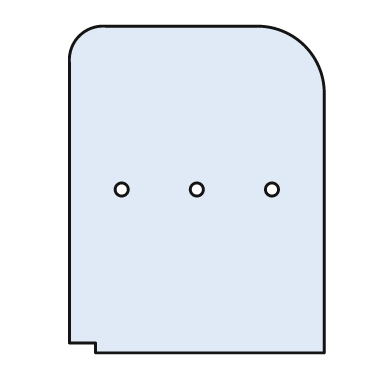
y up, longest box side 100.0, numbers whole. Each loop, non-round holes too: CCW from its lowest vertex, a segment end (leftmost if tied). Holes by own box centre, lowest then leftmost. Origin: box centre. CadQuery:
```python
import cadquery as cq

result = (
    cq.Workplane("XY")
    .moveTo(-31.0, -50.0)
    .lineTo(39.0, -50.0)
    .lineTo(39.0, 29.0)
    .threePointArc((33.0, 44.0), (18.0, 50.0))
    .lineTo(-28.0, 50.0)
    .threePointArc((-36.0, 47.0), (-39.0, 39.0))
    .lineTo(-39.0, -47.0)
    .lineTo(-31.0, -47.0)
    .close()
    .moveTo(-23.0, 0.0)
    .circle(2.0)
    .moveTo(0.0, 0.0)
    .circle(2.0)
    .moveTo(23.0, 0.0)
    .circle(2.0)
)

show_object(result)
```